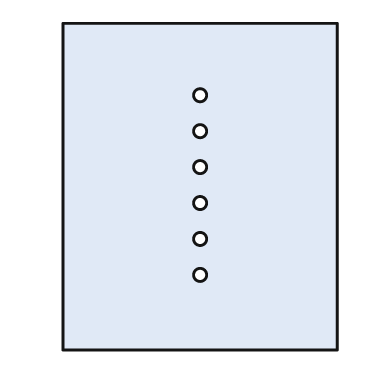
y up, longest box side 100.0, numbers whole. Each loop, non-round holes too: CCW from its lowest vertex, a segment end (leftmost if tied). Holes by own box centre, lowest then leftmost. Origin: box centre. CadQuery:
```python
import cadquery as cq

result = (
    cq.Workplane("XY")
    .moveTo(-42.0, -50.0)
    .lineTo(42.0, -50.0)
    .lineTo(42.0, 50.0)
    .lineTo(-42.0, 50.0)
    .close()
    .moveTo(0.0, -27.0)
    .circle(2.0)
    .moveTo(0.0, -16.0)
    .circle(2.0)
    .moveTo(0.0, -5.0)
    .circle(2.0)
    .moveTo(0.0, 6.0)
    .circle(2.0)
    .moveTo(0.0, 17.0)
    .circle(2.0)
    .moveTo(0.0, 28.0)
    .circle(2.0)
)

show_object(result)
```